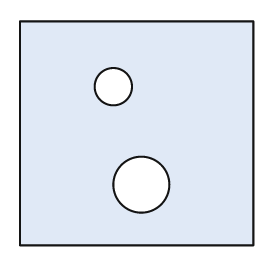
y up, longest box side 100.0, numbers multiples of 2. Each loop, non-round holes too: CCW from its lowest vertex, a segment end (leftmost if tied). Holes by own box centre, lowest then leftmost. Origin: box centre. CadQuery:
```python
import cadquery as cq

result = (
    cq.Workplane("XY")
    .moveTo(-50.0, -48.0)
    .lineTo(50.0, -48.0)
    .lineTo(50.0, 48.0)
    .lineTo(-50.0, 48.0)
    .close()
    .moveTo(2.0, -22.0)
    .circle(12.0)
    .moveTo(-10.0, 20.0)
    .circle(8.0)
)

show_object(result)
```